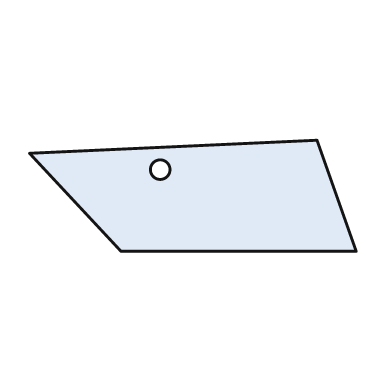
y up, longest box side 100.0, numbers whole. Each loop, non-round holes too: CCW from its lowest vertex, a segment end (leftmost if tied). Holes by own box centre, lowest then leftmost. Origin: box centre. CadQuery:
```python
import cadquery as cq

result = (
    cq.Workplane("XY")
    .moveTo(-22.0, -17.0)
    .lineTo(50.0, -17.0)
    .lineTo(38.0, 17.0)
    .lineTo(-50.0, 13.0)
    .close()
    .moveTo(-10.0, 8.0)
    .circle(3.0)
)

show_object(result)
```